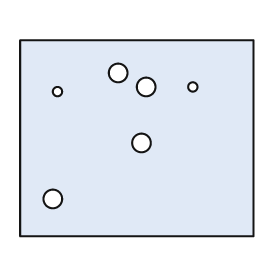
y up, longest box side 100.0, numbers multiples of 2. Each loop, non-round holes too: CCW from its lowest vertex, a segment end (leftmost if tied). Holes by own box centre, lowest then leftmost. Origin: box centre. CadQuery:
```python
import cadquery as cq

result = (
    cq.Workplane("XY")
    .moveTo(-50.0, -42.0)
    .lineTo(50.0, -42.0)
    .lineTo(50.0, 42.0)
    .lineTo(-50.0, 42.0)
    .close()
    .moveTo(-36.0, -26.0)
    .circle(4.0)
    .moveTo(2.0, -2.0)
    .circle(4.0)
    .moveTo(-34.0, 20.0)
    .circle(2.0)
    .moveTo(4.0, 22.0)
    .circle(4.0)
    .moveTo(24.0, 22.0)
    .circle(2.0)
    .moveTo(-8.0, 28.0)
    .circle(4.0)
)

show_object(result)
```